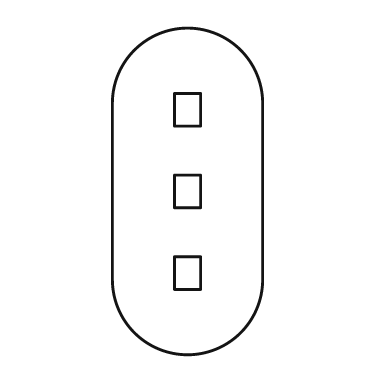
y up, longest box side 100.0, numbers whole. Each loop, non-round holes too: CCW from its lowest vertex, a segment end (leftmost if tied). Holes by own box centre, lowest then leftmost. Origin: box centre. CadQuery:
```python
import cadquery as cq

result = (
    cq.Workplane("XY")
    .moveTo(-23.0, -27.0)
    .threePointArc((0.0, -50.0), (23.0, -27.0))
    .lineTo(23.0, 27.0)
    .threePointArc((0.0, 50.0), (-23.0, 27.0))
    .close()
    .moveTo(-4.0, -30.0)
    .lineTo(4.0, -30.0)
    .lineTo(4.0, -20.0)
    .lineTo(-4.0, -20.0)
    .close()
    .moveTo(-4.0, -5.0)
    .lineTo(4.0, -5.0)
    .lineTo(4.0, 5.0)
    .lineTo(-4.0, 5.0)
    .close()
    .moveTo(-4.0, 20.0)
    .lineTo(4.0, 20.0)
    .lineTo(4.0, 30.0)
    .lineTo(-4.0, 30.0)
    .close()
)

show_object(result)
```